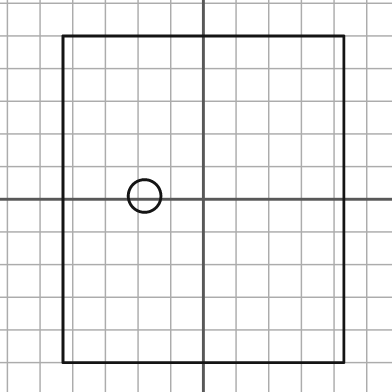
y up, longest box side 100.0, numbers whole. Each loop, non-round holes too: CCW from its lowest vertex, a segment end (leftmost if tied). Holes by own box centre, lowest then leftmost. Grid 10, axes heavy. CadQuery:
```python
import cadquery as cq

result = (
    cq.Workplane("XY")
    .moveTo(-43.0, -50.0)
    .lineTo(43.0, -50.0)
    .lineTo(43.0, 50.0)
    .lineTo(-43.0, 50.0)
    .close()
    .moveTo(-18.0, 1.0)
    .circle(5.0)
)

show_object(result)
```